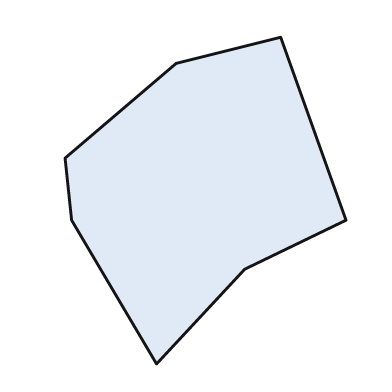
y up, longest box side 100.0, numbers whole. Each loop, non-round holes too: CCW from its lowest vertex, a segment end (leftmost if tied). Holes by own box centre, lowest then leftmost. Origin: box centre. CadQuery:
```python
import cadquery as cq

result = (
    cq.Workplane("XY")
    .moveTo(-15.0, -50.0)
    .lineTo(12.0, -21.0)
    .lineTo(43.0, -6.0)
    .lineTo(23.0, 50.0)
    .lineTo(-9.0, 42.0)
    .lineTo(-43.0, 13.0)
    .lineTo(-41.0, -6.0)
    .close()
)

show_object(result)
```